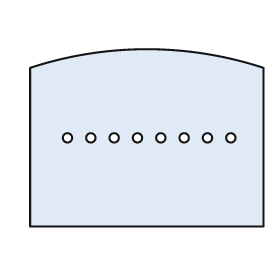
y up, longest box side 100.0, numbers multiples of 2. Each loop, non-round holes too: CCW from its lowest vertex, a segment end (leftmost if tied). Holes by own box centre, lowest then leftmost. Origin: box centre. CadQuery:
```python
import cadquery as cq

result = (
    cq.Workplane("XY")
    .moveTo(-50.0, -38.0)
    .lineTo(50.0, -38.0)
    .lineTo(50.0, 30.0)
    .threePointArc((0.0, 38.0), (-50.0, 30.0))
    .close()
    .moveTo(-34.0, 0.0)
    .circle(2.0)
    .moveTo(-24.0, 0.0)
    .circle(2.0)
    .moveTo(-14.0, 0.0)
    .circle(2.0)
    .moveTo(-4.0, 0.0)
    .circle(2.0)
    .moveTo(6.0, 0.0)
    .circle(2.0)
    .moveTo(16.0, 0.0)
    .circle(2.0)
    .moveTo(26.0, 0.0)
    .circle(2.0)
    .moveTo(36.0, 0.0)
    .circle(2.0)
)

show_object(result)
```